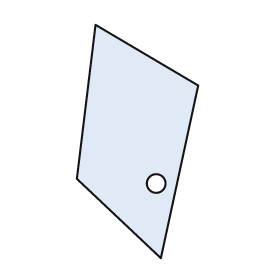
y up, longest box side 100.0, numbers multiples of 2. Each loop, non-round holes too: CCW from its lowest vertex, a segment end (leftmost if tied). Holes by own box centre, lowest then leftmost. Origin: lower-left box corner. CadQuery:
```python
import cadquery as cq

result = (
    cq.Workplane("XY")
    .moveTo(36.0, 0.0)
    .lineTo(52.0, 74.0)
    .lineTo(8.0, 100.0)
    .lineTo(0.0, 34.0)
    .close()
    .moveTo(34.0, 32.0)
    .circle(4.0)
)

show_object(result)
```